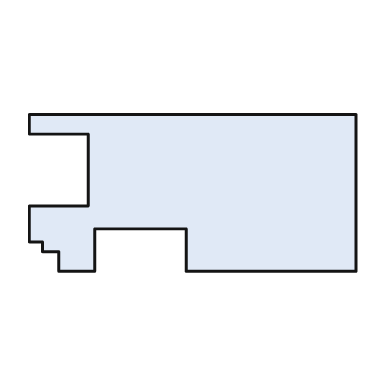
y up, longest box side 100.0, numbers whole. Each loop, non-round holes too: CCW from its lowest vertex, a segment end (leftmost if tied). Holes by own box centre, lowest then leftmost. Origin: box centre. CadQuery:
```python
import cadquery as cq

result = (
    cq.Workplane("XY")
    .moveTo(-41.0, -24.0)
    .lineTo(-30.0, -24.0)
    .lineTo(-30.0, -11.0)
    .lineTo(-2.0, -11.0)
    .lineTo(-2.0, -24.0)
    .lineTo(50.0, -24.0)
    .lineTo(50.0, 24.0)
    .lineTo(-50.0, 24.0)
    .lineTo(-50.0, 18.0)
    .lineTo(-32.0, 18.0)
    .lineTo(-32.0, -4.0)
    .lineTo(-50.0, -4.0)
    .lineTo(-50.0, -15.0)
    .lineTo(-46.0, -15.0)
    .lineTo(-46.0, -18.0)
    .lineTo(-41.0, -18.0)
    .close()
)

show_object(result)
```